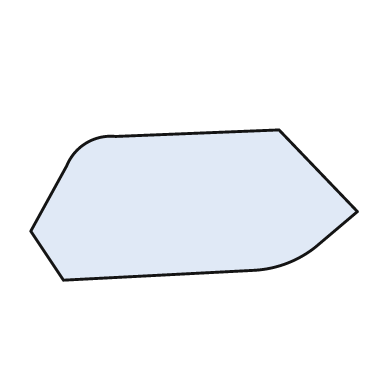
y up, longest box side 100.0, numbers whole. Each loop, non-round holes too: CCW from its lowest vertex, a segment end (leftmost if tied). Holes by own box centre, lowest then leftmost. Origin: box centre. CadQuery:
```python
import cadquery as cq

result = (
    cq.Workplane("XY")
    .moveTo(-40.0, -23.0)
    .lineTo(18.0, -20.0)
    .threePointArc((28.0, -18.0), (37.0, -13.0))
    .lineTo(50.0, -2.0)
    .lineTo(26.0, 23.0)
    .lineTo(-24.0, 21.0)
    .threePointArc((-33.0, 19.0), (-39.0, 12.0))
    .lineTo(-50.0, -8.0)
    .close()
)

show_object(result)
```